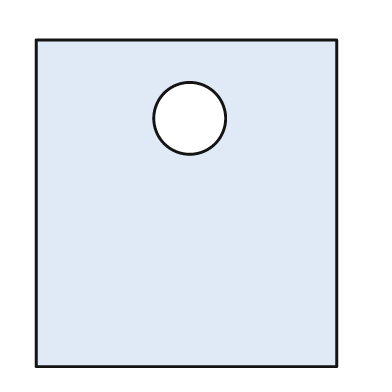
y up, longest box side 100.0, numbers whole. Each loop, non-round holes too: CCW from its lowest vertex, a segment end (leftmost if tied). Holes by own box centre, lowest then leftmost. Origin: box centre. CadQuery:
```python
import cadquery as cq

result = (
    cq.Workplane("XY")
    .moveTo(-46.0, -50.0)
    .lineTo(46.0, -50.0)
    .lineTo(46.0, 50.0)
    .lineTo(-46.0, 50.0)
    .close()
    .moveTo(1.0, 26.0)
    .circle(11.0)
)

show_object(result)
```